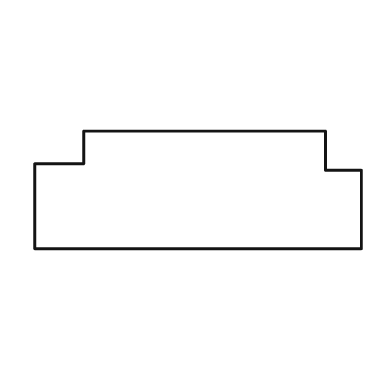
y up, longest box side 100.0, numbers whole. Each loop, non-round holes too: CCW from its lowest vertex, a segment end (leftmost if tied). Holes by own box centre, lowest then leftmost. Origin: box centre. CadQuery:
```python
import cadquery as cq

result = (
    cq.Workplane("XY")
    .moveTo(-50.0, -18.0)
    .lineTo(50.0, -18.0)
    .lineTo(50.0, 6.0)
    .lineTo(39.0, 6.0)
    .lineTo(39.0, 18.0)
    .lineTo(-35.0, 18.0)
    .lineTo(-35.0, 8.0)
    .lineTo(-50.0, 8.0)
    .close()
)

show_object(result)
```